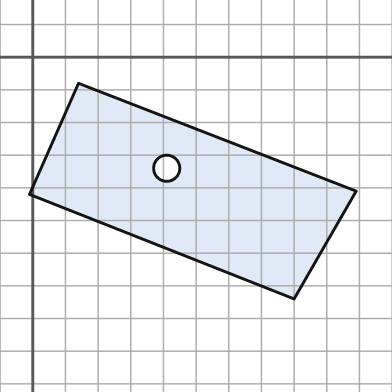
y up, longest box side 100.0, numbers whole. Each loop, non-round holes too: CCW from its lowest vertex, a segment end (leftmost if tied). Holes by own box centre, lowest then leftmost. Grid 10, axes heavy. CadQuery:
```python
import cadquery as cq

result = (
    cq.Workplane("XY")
    .moveTo(80.0, -74.0)
    .lineTo(99.0, -41.0)
    .lineTo(14.0, -8.0)
    .lineTo(-1.0, -42.0)
    .close()
    .moveTo(41.0, -34.0)
    .circle(4.0)
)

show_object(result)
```